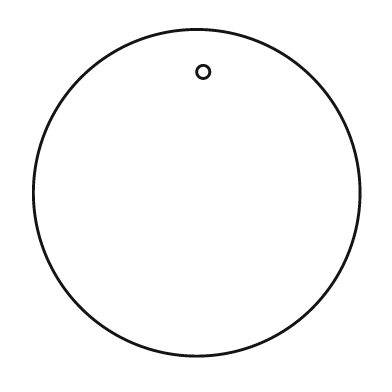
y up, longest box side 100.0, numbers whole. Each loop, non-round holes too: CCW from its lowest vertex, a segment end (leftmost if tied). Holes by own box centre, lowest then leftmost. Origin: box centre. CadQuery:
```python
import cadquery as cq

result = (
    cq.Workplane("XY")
    .moveTo(0.0, 0.0)
    .circle(50.0)
    .moveTo(2.0, 37.0)
    .circle(2.0)
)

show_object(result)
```